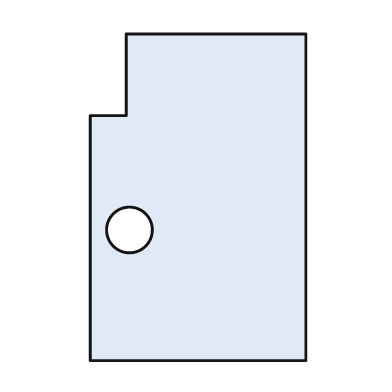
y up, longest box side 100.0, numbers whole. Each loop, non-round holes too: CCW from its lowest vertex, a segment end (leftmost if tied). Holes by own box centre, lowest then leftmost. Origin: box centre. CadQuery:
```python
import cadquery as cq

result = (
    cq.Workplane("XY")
    .moveTo(-33.0, -50.0)
    .lineTo(33.0, -50.0)
    .lineTo(33.0, 50.0)
    .lineTo(-22.0, 50.0)
    .lineTo(-22.0, 25.0)
    .lineTo(-33.0, 25.0)
    .close()
    .moveTo(-21.0, -10.0)
    .circle(7.0)
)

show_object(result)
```